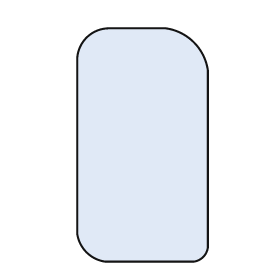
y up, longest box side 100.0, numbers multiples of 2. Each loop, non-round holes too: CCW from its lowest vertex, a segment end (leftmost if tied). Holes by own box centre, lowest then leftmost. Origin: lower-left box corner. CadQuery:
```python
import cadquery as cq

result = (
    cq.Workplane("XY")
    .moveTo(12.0, 0.0)
    .lineTo(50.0, 0.0)
    .threePointArc((54.0, 2.0), (56.0, 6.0))
    .lineTo(56.0, 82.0)
    .threePointArc((50.0, 94.0), (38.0, 100.0))
    .lineTo(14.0, 100.0)
    .threePointArc((4.0, 96.0), (0.0, 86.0))
    .lineTo(0.0, 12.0)
    .threePointArc((4.0, 4.0), (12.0, 0.0))
    .close()
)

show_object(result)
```